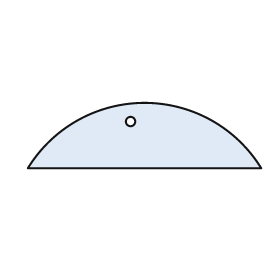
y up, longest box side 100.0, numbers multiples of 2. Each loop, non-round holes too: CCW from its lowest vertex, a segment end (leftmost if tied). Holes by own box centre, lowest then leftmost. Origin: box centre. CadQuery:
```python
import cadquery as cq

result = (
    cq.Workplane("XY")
    .moveTo(-50.0, -14.0)
    .lineTo(50.0, -14.0)
    .threePointArc((0.0, 14.0), (-50.0, -14.0))
    .close()
    .moveTo(-6.0, 6.0)
    .circle(2.0)
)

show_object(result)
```